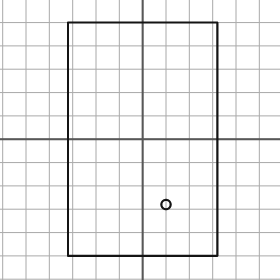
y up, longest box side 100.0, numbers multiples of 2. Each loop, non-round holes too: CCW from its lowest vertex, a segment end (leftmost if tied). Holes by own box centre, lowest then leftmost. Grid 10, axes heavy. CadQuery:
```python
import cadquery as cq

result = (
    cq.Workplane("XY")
    .moveTo(-32.0, -50.0)
    .lineTo(32.0, -50.0)
    .lineTo(32.0, 50.0)
    .lineTo(-32.0, 50.0)
    .close()
    .moveTo(10.0, -28.0)
    .circle(2.0)
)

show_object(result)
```